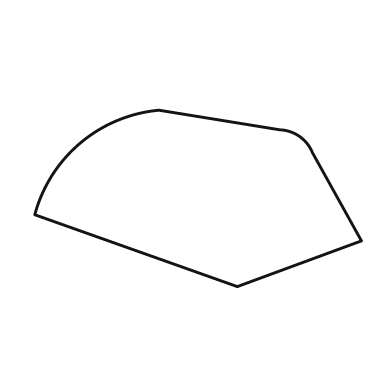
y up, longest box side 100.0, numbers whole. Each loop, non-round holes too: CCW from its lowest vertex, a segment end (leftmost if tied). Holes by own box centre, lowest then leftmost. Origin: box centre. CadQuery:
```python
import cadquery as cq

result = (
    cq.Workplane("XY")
    .moveTo(12.0, -27.0)
    .lineTo(50.0, -13.0)
    .lineTo(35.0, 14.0)
    .threePointArc((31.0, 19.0), (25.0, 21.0))
    .lineTo(-12.0, 27.0)
    .threePointArc((-36.0, 17.0), (-50.0, -5.0))
    .close()
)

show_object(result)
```